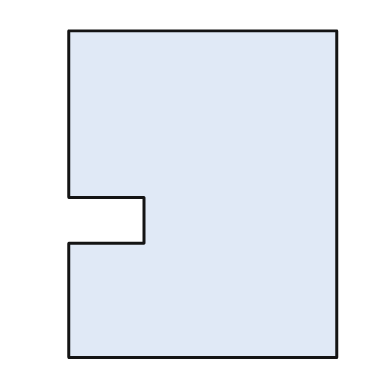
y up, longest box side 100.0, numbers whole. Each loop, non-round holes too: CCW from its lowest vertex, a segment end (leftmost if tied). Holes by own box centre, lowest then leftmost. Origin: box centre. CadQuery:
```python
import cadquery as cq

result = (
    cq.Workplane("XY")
    .moveTo(-41.0, -50.0)
    .lineTo(41.0, -50.0)
    .lineTo(41.0, 50.0)
    .lineTo(-41.0, 50.0)
    .lineTo(-41.0, -1.0)
    .lineTo(-18.0, -1.0)
    .lineTo(-18.0, -15.0)
    .lineTo(-41.0, -15.0)
    .close()
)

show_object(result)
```